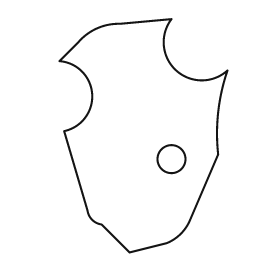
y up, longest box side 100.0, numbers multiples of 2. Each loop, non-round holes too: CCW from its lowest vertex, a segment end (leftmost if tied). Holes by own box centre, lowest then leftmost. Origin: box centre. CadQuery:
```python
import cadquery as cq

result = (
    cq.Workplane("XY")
    .moveTo(-6.0, -50.0)
    .lineTo(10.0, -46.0)
    .threePointArc((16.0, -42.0), (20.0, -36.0))
    .lineTo(32.0, -8.0)
    .threePointArc((32.0, 10.0), (36.0, 28.0))
    .threePointArc((14.0, 28.0), (12.0, 50.0))
    .lineTo(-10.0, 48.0)
    .threePointArc((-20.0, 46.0), (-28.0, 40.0))
    .lineTo(-36.0, 32.0)
    .threePointArc((-22.0, 18.0), (-34.0, 2.0))
    .lineTo(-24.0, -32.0)
    .threePointArc((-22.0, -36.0), (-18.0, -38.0))
    .close()
    .moveTo(12.0, -10.0)
    .circle(6.0)
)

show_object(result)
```